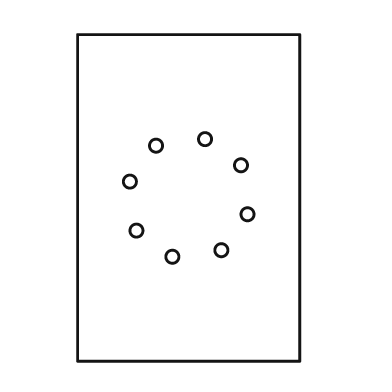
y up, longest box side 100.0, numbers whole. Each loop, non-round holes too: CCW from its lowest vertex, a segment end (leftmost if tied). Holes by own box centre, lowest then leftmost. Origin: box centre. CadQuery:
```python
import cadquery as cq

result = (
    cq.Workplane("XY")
    .moveTo(-34.0, -50.0)
    .lineTo(34.0, -50.0)
    .lineTo(34.0, 50.0)
    .lineTo(-34.0, 50.0)
    .close()
    .moveTo(-5.0, -18.0)
    .circle(2.0)
    .moveTo(10.0, -16.0)
    .circle(2.0)
    .moveTo(-16.0, -10.0)
    .circle(2.0)
    .moveTo(18.0, -5.0)
    .circle(2.0)
    .moveTo(-18.0, 5.0)
    .circle(2.0)
    .moveTo(16.0, 10.0)
    .circle(2.0)
    .moveTo(-10.0, 16.0)
    .circle(2.0)
    .moveTo(5.0, 18.0)
    .circle(2.0)
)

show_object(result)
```